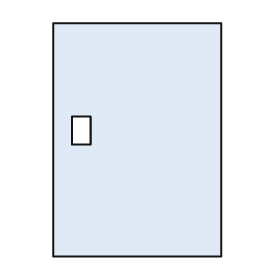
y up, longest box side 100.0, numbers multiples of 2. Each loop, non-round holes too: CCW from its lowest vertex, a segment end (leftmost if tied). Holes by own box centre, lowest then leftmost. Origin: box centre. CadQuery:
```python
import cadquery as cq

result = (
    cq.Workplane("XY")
    .moveTo(-36.0, -50.0)
    .lineTo(36.0, -50.0)
    .lineTo(36.0, 50.0)
    .lineTo(-36.0, 50.0)
    .close()
    .moveTo(-28.0, -2.0)
    .lineTo(-20.0, -2.0)
    .lineTo(-20.0, 10.0)
    .lineTo(-28.0, 10.0)
    .close()
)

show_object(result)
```